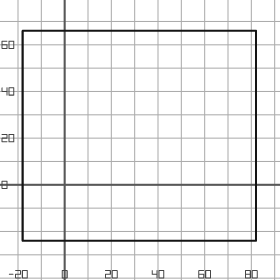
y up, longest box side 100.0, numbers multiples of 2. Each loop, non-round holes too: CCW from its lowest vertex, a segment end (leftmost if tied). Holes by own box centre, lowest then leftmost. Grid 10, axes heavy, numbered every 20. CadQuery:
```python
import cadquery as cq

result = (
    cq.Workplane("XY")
    .moveTo(-18.0, -24.0)
    .lineTo(82.0, -24.0)
    .lineTo(82.0, 66.0)
    .lineTo(-18.0, 66.0)
    .close()
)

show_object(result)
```